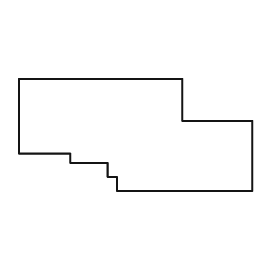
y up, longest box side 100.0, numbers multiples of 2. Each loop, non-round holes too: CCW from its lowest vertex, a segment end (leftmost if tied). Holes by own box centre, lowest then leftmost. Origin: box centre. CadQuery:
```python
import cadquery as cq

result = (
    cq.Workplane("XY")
    .moveTo(-8.0, -24.0)
    .lineTo(50.0, -24.0)
    .lineTo(50.0, 6.0)
    .lineTo(20.0, 6.0)
    .lineTo(20.0, 24.0)
    .lineTo(-50.0, 24.0)
    .lineTo(-50.0, -8.0)
    .lineTo(-28.0, -8.0)
    .lineTo(-28.0, -12.0)
    .lineTo(-12.0, -12.0)
    .lineTo(-12.0, -18.0)
    .lineTo(-8.0, -18.0)
    .close()
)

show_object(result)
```